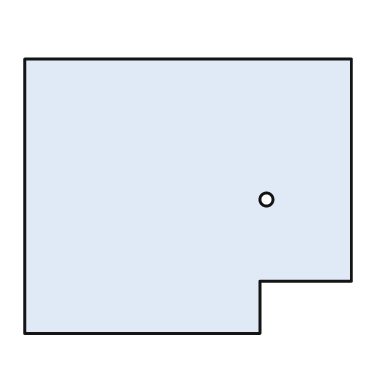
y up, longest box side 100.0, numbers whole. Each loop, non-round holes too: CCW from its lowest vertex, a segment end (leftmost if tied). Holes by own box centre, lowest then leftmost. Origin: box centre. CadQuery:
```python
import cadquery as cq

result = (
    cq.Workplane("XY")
    .moveTo(-50.0, -42.0)
    .lineTo(22.0, -42.0)
    .lineTo(22.0, -26.0)
    .lineTo(50.0, -26.0)
    .lineTo(50.0, 42.0)
    .lineTo(-50.0, 42.0)
    .close()
    .moveTo(24.0, -1.0)
    .circle(2.0)
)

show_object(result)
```